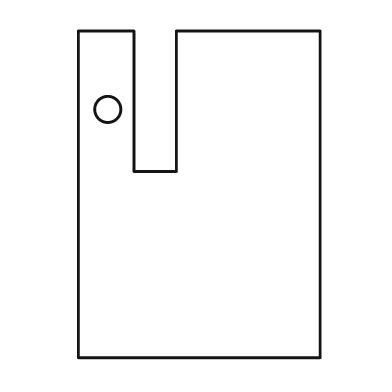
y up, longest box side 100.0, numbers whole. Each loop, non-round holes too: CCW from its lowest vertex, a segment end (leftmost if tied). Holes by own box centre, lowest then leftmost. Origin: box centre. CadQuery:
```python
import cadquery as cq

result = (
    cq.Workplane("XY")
    .moveTo(-37.0, -50.0)
    .lineTo(37.0, -50.0)
    .lineTo(37.0, 50.0)
    .lineTo(-7.0, 50.0)
    .lineTo(-7.0, 7.0)
    .lineTo(-20.0, 7.0)
    .lineTo(-20.0, 50.0)
    .lineTo(-37.0, 50.0)
    .close()
    .moveTo(-28.0, 26.0)
    .circle(4.0)
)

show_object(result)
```